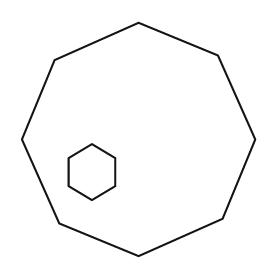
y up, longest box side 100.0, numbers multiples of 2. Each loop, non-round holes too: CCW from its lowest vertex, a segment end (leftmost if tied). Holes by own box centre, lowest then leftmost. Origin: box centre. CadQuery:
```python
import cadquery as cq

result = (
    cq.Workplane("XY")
    .moveTo(0.0, -50.0)
    .lineTo(36.0, -34.0)
    .lineTo(50.0, 0.0)
    .lineTo(34.0, 36.0)
    .lineTo(0.0, 50.0)
    .lineTo(-36.0, 34.0)
    .lineTo(-50.0, 0.0)
    .lineTo(-34.0, -36.0)
    .close()
    .moveTo(-20.0, -26.0)
    .lineTo(-10.0, -20.0)
    .lineTo(-10.0, -8.0)
    .lineTo(-20.0, -2.0)
    .lineTo(-30.0, -8.0)
    .lineTo(-30.0, -20.0)
    .close()
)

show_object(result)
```